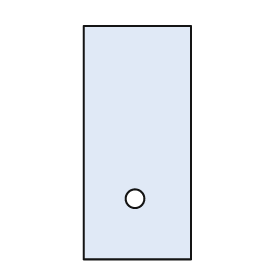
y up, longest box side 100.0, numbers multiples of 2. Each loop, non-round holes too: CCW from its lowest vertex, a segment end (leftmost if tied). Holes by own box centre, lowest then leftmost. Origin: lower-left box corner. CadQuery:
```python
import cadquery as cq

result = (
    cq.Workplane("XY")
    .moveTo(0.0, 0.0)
    .lineTo(46.0, 0.0)
    .lineTo(46.0, 100.0)
    .lineTo(0.0, 100.0)
    .close()
    .moveTo(22.0, 26.0)
    .circle(4.0)
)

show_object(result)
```